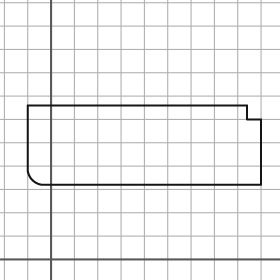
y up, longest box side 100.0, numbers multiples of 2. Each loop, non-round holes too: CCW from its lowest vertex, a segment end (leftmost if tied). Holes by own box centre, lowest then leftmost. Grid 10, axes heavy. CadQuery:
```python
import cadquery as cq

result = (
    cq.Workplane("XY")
    .moveTo(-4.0, 32.0)
    .lineTo(90.0, 32.0)
    .lineTo(90.0, 60.0)
    .lineTo(84.0, 60.0)
    .lineTo(84.0, 66.0)
    .lineTo(-10.0, 66.0)
    .lineTo(-10.0, 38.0)
    .threePointArc((-8.0, 34.0), (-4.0, 32.0))
    .close()
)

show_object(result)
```